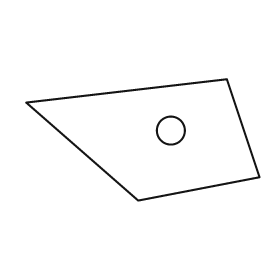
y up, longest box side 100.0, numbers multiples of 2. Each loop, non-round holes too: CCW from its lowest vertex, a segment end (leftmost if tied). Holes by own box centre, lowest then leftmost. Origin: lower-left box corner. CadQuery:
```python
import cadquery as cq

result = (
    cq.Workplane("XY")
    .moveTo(48.0, 0.0)
    .lineTo(100.0, 10.0)
    .lineTo(86.0, 52.0)
    .lineTo(0.0, 42.0)
    .close()
    .moveTo(62.0, 30.0)
    .circle(6.0)
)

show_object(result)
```